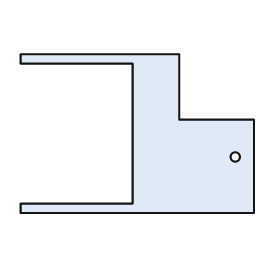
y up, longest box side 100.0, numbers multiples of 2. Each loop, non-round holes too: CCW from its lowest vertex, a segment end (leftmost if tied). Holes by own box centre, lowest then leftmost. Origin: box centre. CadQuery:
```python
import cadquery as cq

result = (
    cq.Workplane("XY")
    .moveTo(-50.0, -34.0)
    .lineTo(50.0, -34.0)
    .lineTo(50.0, 6.0)
    .lineTo(18.0, 6.0)
    .lineTo(18.0, 34.0)
    .lineTo(-50.0, 34.0)
    .lineTo(-50.0, 30.0)
    .lineTo(-2.0, 30.0)
    .lineTo(-2.0, -30.0)
    .lineTo(-50.0, -30.0)
    .close()
    .moveTo(42.0, -10.0)
    .circle(2.0)
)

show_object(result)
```